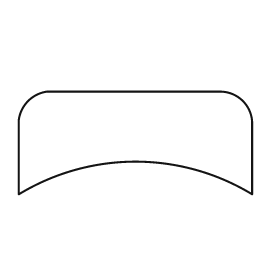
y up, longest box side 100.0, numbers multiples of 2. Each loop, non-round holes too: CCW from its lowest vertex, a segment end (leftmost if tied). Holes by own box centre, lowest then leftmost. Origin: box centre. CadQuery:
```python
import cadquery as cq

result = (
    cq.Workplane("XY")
    .moveTo(-50.0, -22.0)
    .threePointArc((0.0, -8.0), (50.0, -22.0))
    .lineTo(50.0, 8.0)
    .threePointArc((46.0, 18.0), (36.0, 22.0))
    .lineTo(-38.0, 22.0)
    .threePointArc((-46.0, 18.0), (-50.0, 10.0))
    .close()
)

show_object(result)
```